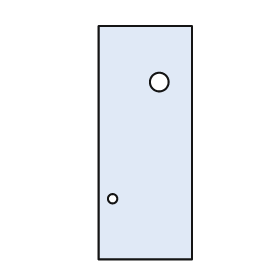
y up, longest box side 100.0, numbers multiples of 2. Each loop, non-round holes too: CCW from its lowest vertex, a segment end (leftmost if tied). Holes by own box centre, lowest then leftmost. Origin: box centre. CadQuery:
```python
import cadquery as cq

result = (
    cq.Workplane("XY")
    .moveTo(-20.0, -50.0)
    .lineTo(20.0, -50.0)
    .lineTo(20.0, 50.0)
    .lineTo(-20.0, 50.0)
    .close()
    .moveTo(-14.0, -24.0)
    .circle(2.0)
    .moveTo(6.0, 26.0)
    .circle(4.0)
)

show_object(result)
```